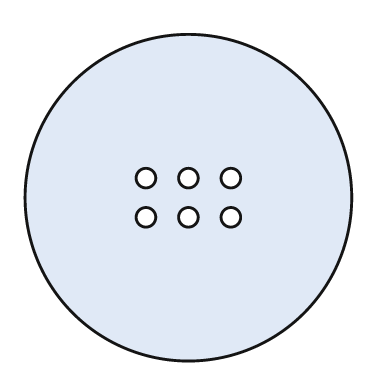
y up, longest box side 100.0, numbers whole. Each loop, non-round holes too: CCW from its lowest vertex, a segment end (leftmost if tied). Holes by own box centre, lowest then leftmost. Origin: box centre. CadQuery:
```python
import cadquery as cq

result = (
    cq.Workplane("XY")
    .moveTo(0.0, 0.0)
    .circle(50.0)
    .moveTo(-13.0, -6.0)
    .circle(3.0)
    .moveTo(0.0, -6.0)
    .circle(3.0)
    .moveTo(13.0, -6.0)
    .circle(3.0)
    .moveTo(-13.0, 6.0)
    .circle(3.0)
    .moveTo(0.0, 6.0)
    .circle(3.0)
    .moveTo(13.0, 6.0)
    .circle(3.0)
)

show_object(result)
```